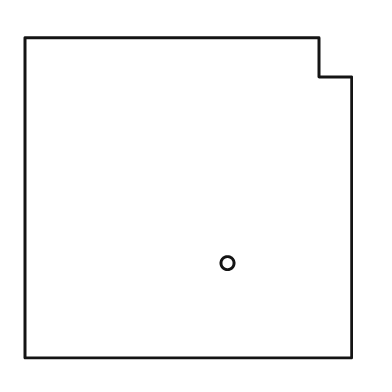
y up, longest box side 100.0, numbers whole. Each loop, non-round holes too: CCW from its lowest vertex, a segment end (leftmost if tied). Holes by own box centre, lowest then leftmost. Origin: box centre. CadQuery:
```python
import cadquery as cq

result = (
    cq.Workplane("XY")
    .moveTo(-50.0, -49.0)
    .lineTo(50.0, -49.0)
    .lineTo(50.0, 37.0)
    .lineTo(40.0, 37.0)
    .lineTo(40.0, 49.0)
    .lineTo(-50.0, 49.0)
    .close()
    .moveTo(12.0, -20.0)
    .circle(2.0)
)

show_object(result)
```